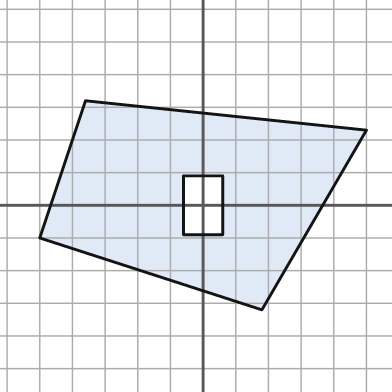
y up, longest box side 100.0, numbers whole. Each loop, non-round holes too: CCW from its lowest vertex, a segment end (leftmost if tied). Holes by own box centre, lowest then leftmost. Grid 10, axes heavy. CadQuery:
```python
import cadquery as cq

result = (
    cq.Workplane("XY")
    .moveTo(18.0, -32.0)
    .lineTo(50.0, 23.0)
    .lineTo(-36.0, 32.0)
    .lineTo(-50.0, -10.0)
    .close()
    .moveTo(-6.0, -9.0)
    .lineTo(6.0, -9.0)
    .lineTo(6.0, 9.0)
    .lineTo(-6.0, 9.0)
    .close()
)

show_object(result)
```